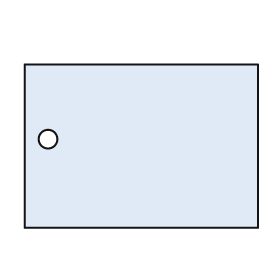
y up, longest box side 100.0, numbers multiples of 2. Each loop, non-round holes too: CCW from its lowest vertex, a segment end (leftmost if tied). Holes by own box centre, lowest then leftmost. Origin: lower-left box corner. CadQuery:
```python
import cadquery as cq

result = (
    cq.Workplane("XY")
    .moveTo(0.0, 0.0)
    .lineTo(100.0, 0.0)
    .lineTo(100.0, 70.0)
    .lineTo(0.0, 70.0)
    .close()
    .moveTo(10.0, 38.0)
    .circle(4.0)
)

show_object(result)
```